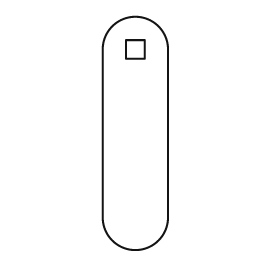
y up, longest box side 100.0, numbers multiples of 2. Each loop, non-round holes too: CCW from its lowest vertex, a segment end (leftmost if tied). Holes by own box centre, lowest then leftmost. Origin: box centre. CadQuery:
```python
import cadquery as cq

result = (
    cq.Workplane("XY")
    .moveTo(-14.0, -36.0)
    .threePointArc((0.0, -50.0), (14.0, -36.0))
    .lineTo(14.0, 36.0)
    .threePointArc((0.0, 50.0), (-14.0, 36.0))
    .close()
    .moveTo(-4.0, 32.0)
    .lineTo(4.0, 32.0)
    .lineTo(4.0, 40.0)
    .lineTo(-4.0, 40.0)
    .close()
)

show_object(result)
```